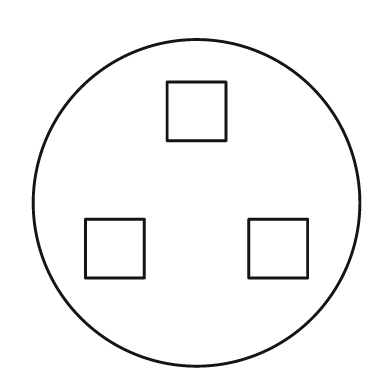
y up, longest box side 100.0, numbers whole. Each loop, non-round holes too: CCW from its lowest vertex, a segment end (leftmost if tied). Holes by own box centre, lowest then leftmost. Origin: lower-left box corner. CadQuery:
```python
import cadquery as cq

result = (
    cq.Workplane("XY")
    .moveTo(50.0, 50.0)
    .circle(50.0)
    .moveTo(16.0, 27.0)
    .lineTo(34.0, 27.0)
    .lineTo(34.0, 45.0)
    .lineTo(16.0, 45.0)
    .close()
    .moveTo(66.0, 27.0)
    .lineTo(84.0, 27.0)
    .lineTo(84.0, 45.0)
    .lineTo(66.0, 45.0)
    .close()
    .moveTo(41.0, 69.0)
    .lineTo(59.0, 69.0)
    .lineTo(59.0, 87.0)
    .lineTo(41.0, 87.0)
    .close()
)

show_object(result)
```